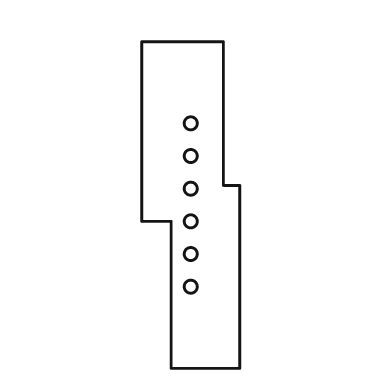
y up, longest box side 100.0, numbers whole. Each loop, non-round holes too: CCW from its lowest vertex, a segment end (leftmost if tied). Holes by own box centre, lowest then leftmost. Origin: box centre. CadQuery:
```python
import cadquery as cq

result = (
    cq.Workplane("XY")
    .moveTo(-6.0, -50.0)
    .lineTo(15.0, -50.0)
    .lineTo(15.0, 6.0)
    .lineTo(10.0, 6.0)
    .lineTo(10.0, 50.0)
    .lineTo(-15.0, 50.0)
    .lineTo(-15.0, -5.0)
    .lineTo(-6.0, -5.0)
    .close()
    .moveTo(0.0, -25.0)
    .circle(2.0)
    .moveTo(0.0, -15.0)
    .circle(2.0)
    .moveTo(0.0, -5.0)
    .circle(2.0)
    .moveTo(0.0, 5.0)
    .circle(2.0)
    .moveTo(0.0, 15.0)
    .circle(2.0)
    .moveTo(0.0, 25.0)
    .circle(2.0)
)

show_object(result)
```